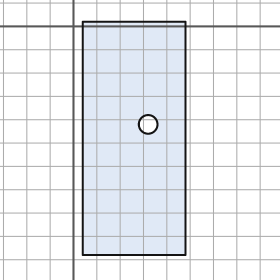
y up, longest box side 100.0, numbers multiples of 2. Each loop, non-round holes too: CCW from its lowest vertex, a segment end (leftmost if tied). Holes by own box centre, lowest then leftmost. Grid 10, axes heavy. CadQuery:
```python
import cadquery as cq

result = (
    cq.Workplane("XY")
    .moveTo(4.0, -98.0)
    .lineTo(48.0, -98.0)
    .lineTo(48.0, 2.0)
    .lineTo(4.0, 2.0)
    .close()
    .moveTo(32.0, -42.0)
    .circle(4.0)
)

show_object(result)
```